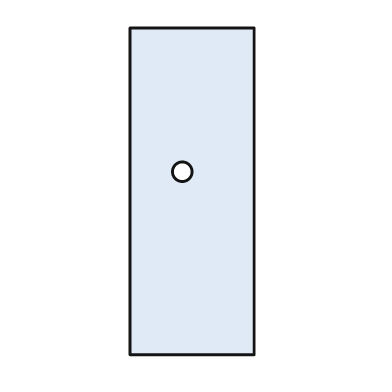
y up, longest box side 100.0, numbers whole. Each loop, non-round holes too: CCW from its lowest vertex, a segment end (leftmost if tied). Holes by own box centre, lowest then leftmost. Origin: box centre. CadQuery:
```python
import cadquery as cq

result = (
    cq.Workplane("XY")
    .moveTo(-19.0, -50.0)
    .lineTo(19.0, -50.0)
    .lineTo(19.0, 50.0)
    .lineTo(-19.0, 50.0)
    .close()
    .moveTo(-3.0, 6.0)
    .circle(3.0)
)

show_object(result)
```